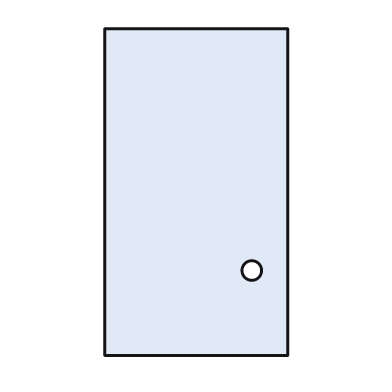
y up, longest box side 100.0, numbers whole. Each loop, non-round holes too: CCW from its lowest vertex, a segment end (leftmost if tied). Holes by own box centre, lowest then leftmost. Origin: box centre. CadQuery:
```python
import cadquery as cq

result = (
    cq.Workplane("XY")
    .moveTo(-28.0, -50.0)
    .lineTo(28.0, -50.0)
    .lineTo(28.0, 50.0)
    .lineTo(-28.0, 50.0)
    .close()
    .moveTo(17.0, -24.0)
    .circle(3.0)
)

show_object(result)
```